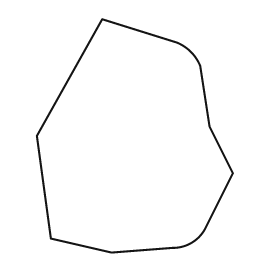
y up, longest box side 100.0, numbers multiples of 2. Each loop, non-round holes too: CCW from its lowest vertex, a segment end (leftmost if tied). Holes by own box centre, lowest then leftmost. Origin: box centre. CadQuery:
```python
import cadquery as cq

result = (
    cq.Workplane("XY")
    .moveTo(-10.0, -50.0)
    .lineTo(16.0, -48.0)
    .threePointArc((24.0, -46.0), (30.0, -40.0))
    .lineTo(42.0, -16.0)
    .lineTo(32.0, 4.0)
    .lineTo(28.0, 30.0)
    .threePointArc((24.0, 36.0), (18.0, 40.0))
    .lineTo(-14.0, 50.0)
    .lineTo(-42.0, 0.0)
    .lineTo(-36.0, -44.0)
    .close()
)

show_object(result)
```